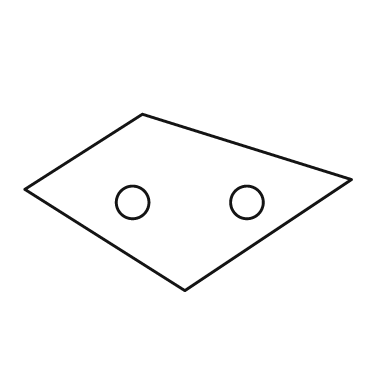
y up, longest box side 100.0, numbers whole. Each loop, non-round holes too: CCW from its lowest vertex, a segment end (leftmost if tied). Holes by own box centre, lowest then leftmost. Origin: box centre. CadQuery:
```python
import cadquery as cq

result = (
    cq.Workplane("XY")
    .moveTo(-1.0, -27.0)
    .lineTo(50.0, 7.0)
    .lineTo(-14.0, 27.0)
    .lineTo(-50.0, 4.0)
    .close()
    .moveTo(-17.0, 0.0)
    .circle(5.0)
    .moveTo(18.0, 0.0)
    .circle(5.0)
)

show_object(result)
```